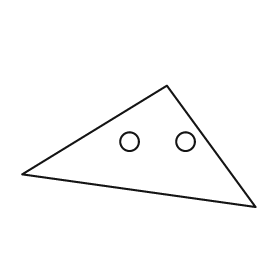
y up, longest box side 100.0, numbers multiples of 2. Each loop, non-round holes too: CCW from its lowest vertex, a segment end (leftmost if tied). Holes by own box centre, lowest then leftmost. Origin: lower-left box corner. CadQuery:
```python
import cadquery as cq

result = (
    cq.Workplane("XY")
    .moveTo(100.0, 0.0)
    .lineTo(62.0, 52.0)
    .lineTo(0.0, 14.0)
    .close()
    .moveTo(46.0, 28.0)
    .circle(4.0)
    .moveTo(70.0, 28.0)
    .circle(4.0)
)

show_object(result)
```